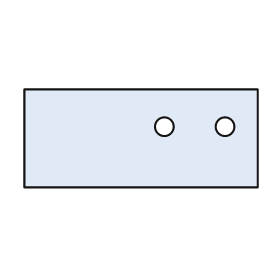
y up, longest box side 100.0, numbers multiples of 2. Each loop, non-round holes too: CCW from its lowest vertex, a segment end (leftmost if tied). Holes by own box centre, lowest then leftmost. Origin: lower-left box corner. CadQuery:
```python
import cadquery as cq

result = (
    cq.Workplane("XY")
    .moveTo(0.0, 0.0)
    .lineTo(100.0, 0.0)
    .lineTo(100.0, 42.0)
    .lineTo(0.0, 42.0)
    .close()
    .moveTo(60.0, 26.0)
    .circle(4.0)
    .moveTo(86.0, 26.0)
    .circle(4.0)
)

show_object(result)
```